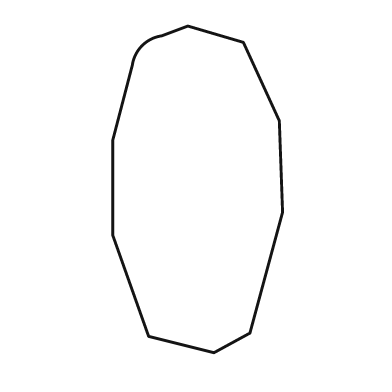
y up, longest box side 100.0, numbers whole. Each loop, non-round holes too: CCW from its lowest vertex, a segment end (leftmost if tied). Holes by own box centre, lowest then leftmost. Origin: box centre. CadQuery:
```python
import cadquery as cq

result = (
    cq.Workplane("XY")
    .moveTo(5.0, -50.0)
    .lineTo(16.0, -44.0)
    .lineTo(26.0, -7.0)
    .lineTo(25.0, 21.0)
    .lineTo(14.0, 45.0)
    .lineTo(-3.0, 50.0)
    .lineTo(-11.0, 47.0)
    .threePointArc((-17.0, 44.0), (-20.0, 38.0))
    .lineTo(-26.0, 15.0)
    .lineTo(-26.0, -14.0)
    .lineTo(-15.0, -45.0)
    .close()
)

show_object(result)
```